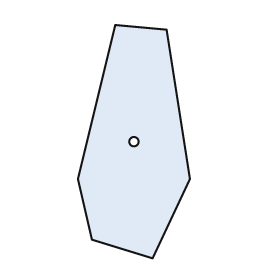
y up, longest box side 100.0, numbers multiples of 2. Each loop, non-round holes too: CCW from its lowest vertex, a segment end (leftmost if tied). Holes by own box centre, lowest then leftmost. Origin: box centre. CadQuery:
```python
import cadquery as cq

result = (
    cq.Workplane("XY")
    .moveTo(8.0, -50.0)
    .lineTo(24.0, -16.0)
    .lineTo(14.0, 48.0)
    .lineTo(-8.0, 50.0)
    .lineTo(-24.0, -16.0)
    .lineTo(-18.0, -42.0)
    .close()
    .moveTo(0.0, 0.0)
    .circle(2.0)
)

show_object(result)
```